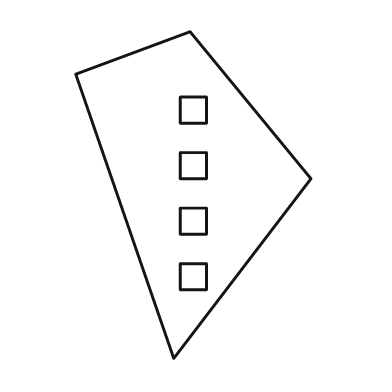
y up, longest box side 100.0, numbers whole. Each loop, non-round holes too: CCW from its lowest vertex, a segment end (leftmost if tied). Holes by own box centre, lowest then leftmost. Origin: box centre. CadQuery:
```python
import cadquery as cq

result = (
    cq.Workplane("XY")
    .moveTo(-6.0, -50.0)
    .lineTo(36.0, 5.0)
    .lineTo(-1.0, 50.0)
    .lineTo(-36.0, 37.0)
    .close()
    .moveTo(-4.0, -29.0)
    .lineTo(4.0, -29.0)
    .lineTo(4.0, -21.0)
    .lineTo(-4.0, -21.0)
    .close()
    .moveTo(-4.0, -12.0)
    .lineTo(4.0, -12.0)
    .lineTo(4.0, -4.0)
    .lineTo(-4.0, -4.0)
    .close()
    .moveTo(-4.0, 5.0)
    .lineTo(4.0, 5.0)
    .lineTo(4.0, 13.0)
    .lineTo(-4.0, 13.0)
    .close()
    .moveTo(-4.0, 22.0)
    .lineTo(4.0, 22.0)
    .lineTo(4.0, 30.0)
    .lineTo(-4.0, 30.0)
    .close()
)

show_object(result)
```